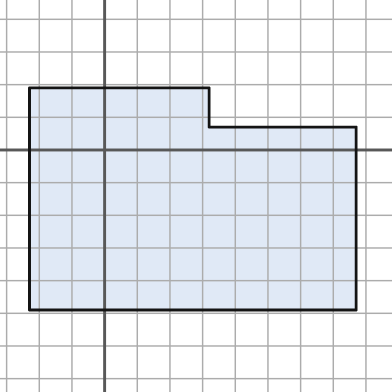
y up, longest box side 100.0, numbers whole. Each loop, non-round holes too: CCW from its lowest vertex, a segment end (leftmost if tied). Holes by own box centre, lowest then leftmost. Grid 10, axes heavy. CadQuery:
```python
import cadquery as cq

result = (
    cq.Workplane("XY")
    .moveTo(-23.0, -49.0)
    .lineTo(77.0, -49.0)
    .lineTo(77.0, 7.0)
    .lineTo(32.0, 7.0)
    .lineTo(32.0, 19.0)
    .lineTo(-23.0, 19.0)
    .close()
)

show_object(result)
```